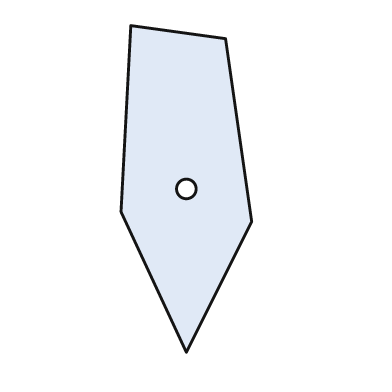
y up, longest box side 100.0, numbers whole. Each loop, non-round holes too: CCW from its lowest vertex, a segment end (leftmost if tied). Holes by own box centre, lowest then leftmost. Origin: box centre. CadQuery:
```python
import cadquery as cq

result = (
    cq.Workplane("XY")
    .moveTo(0.0, -50.0)
    .lineTo(20.0, -10.0)
    .lineTo(12.0, 46.0)
    .lineTo(-17.0, 50.0)
    .lineTo(-20.0, -7.0)
    .close()
    .moveTo(0.0, 0.0)
    .circle(3.0)
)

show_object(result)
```